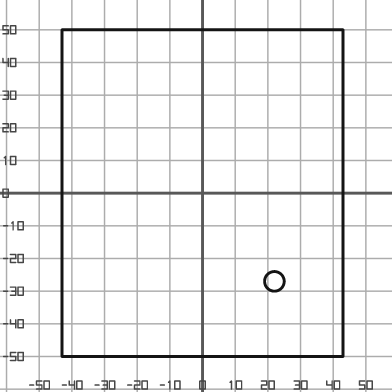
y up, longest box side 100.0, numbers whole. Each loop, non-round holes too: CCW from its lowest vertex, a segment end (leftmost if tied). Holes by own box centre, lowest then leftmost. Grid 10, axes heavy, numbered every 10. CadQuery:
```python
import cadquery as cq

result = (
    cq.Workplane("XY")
    .moveTo(-43.0, -50.0)
    .lineTo(43.0, -50.0)
    .lineTo(43.0, 50.0)
    .lineTo(-43.0, 50.0)
    .close()
    .moveTo(22.0, -27.0)
    .circle(3.0)
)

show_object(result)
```